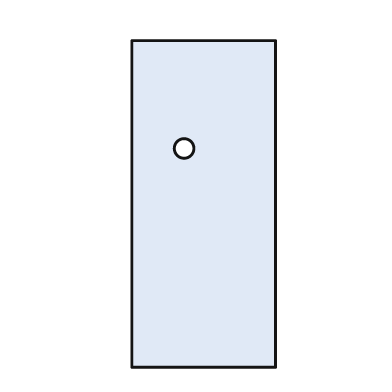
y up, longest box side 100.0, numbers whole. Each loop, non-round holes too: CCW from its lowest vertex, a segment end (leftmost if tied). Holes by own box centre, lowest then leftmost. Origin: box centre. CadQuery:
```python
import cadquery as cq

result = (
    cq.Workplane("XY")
    .moveTo(-22.0, -50.0)
    .lineTo(22.0, -50.0)
    .lineTo(22.0, 50.0)
    .lineTo(-22.0, 50.0)
    .close()
    .moveTo(-6.0, 17.0)
    .circle(3.0)
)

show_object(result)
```